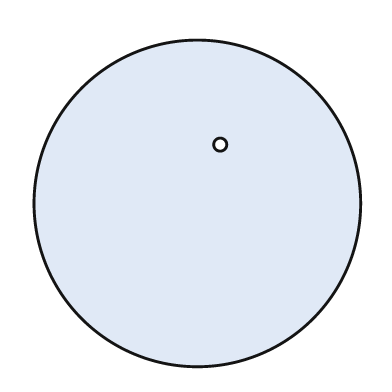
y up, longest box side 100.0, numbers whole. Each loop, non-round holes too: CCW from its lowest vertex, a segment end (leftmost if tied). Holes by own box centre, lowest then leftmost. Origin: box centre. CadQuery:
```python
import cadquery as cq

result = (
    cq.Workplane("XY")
    .moveTo(0.0, 0.0)
    .circle(50.0)
    .moveTo(7.0, 18.0)
    .circle(2.0)
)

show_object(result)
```